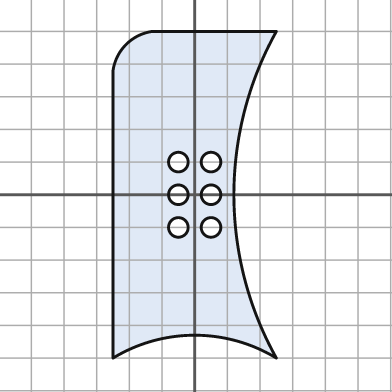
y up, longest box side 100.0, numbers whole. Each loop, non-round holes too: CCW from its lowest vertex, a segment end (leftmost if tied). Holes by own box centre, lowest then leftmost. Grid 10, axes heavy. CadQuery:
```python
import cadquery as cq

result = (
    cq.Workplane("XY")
    .moveTo(-25.0, -50.0)
    .threePointArc((0.0, -43.0), (25.0, -50.0))
    .threePointArc((12.0, 0.0), (25.0, 50.0))
    .lineTo(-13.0, 50.0)
    .threePointArc((-21.0, 46.0), (-25.0, 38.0))
    .close()
    .moveTo(-5.0, -10.0)
    .circle(3.0)
    .moveTo(5.0, -10.0)
    .circle(3.0)
    .moveTo(-5.0, 0.0)
    .circle(3.0)
    .moveTo(5.0, 0.0)
    .circle(3.0)
    .moveTo(-5.0, 10.0)
    .circle(3.0)
    .moveTo(5.0, 10.0)
    .circle(3.0)
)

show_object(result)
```